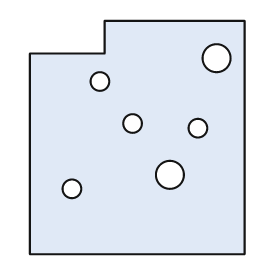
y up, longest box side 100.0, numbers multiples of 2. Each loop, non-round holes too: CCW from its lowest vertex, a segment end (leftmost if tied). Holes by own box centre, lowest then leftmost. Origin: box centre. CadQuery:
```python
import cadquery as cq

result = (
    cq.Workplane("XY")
    .moveTo(-46.0, -50.0)
    .lineTo(46.0, -50.0)
    .lineTo(46.0, 50.0)
    .lineTo(-14.0, 50.0)
    .lineTo(-14.0, 36.0)
    .lineTo(-46.0, 36.0)
    .close()
    .moveTo(-28.0, -22.0)
    .circle(4.0)
    .moveTo(14.0, -16.0)
    .circle(6.0)
    .moveTo(26.0, 4.0)
    .circle(4.0)
    .moveTo(-2.0, 6.0)
    .circle(4.0)
    .moveTo(-16.0, 24.0)
    .circle(4.0)
    .moveTo(34.0, 34.0)
    .circle(6.0)
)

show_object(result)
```